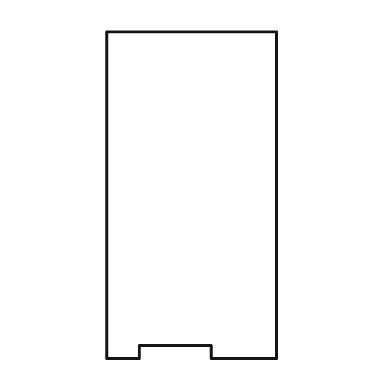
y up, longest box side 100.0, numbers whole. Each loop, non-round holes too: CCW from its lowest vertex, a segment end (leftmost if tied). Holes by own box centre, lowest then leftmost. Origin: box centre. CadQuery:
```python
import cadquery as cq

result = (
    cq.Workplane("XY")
    .moveTo(-26.0, -50.0)
    .lineTo(-16.0, -50.0)
    .lineTo(-16.0, -46.0)
    .lineTo(6.0, -46.0)
    .lineTo(6.0, -50.0)
    .lineTo(26.0, -50.0)
    .lineTo(26.0, 50.0)
    .lineTo(-26.0, 50.0)
    .close()
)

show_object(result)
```